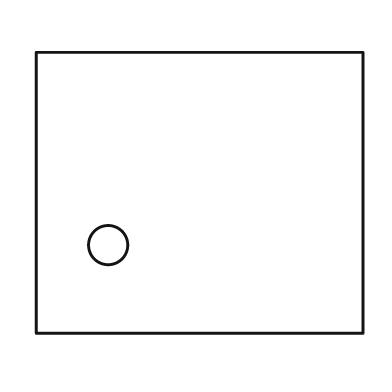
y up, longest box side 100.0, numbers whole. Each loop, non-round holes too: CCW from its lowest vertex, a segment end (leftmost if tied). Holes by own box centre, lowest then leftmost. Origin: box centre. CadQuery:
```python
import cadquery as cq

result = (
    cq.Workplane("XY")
    .moveTo(-50.0, -43.0)
    .lineTo(50.0, -43.0)
    .lineTo(50.0, 43.0)
    .lineTo(-50.0, 43.0)
    .close()
    .moveTo(-28.0, -16.0)
    .circle(6.0)
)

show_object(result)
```